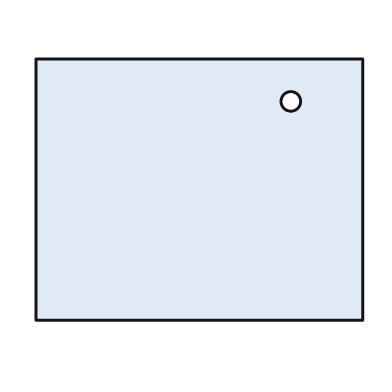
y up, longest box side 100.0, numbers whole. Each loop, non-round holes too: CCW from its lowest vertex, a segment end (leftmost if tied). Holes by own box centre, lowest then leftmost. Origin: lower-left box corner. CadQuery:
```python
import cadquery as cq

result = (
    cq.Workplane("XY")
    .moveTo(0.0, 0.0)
    .lineTo(100.0, 0.0)
    .lineTo(100.0, 80.0)
    .lineTo(0.0, 80.0)
    .close()
    .moveTo(78.0, 67.0)
    .circle(3.0)
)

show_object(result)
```